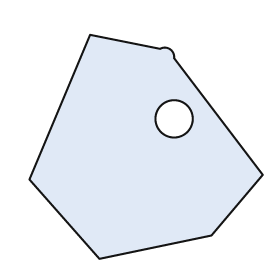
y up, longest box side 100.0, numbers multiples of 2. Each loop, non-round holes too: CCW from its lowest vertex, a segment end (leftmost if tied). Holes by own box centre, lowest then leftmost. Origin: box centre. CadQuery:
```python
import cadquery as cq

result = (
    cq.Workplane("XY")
    .moveTo(-20.0, -48.0)
    .lineTo(28.0, -38.0)
    .lineTo(50.0, -12.0)
    .lineTo(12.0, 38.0)
    .threePointArc((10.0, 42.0), (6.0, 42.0))
    .lineTo(-24.0, 48.0)
    .lineTo(-50.0, -14.0)
    .close()
    .moveTo(12.0, 12.0)
    .circle(8.0)
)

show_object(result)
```